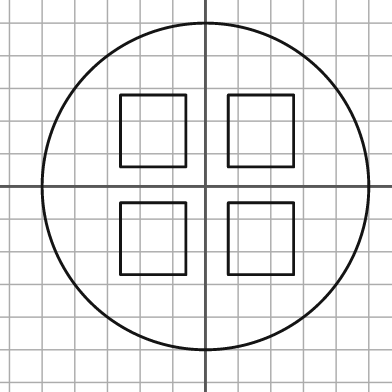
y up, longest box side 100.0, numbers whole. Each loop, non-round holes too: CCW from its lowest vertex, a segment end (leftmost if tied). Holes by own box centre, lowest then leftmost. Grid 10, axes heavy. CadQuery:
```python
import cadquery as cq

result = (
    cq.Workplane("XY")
    .moveTo(0.0, 0.0)
    .circle(50.0)
    .moveTo(-26.0, -27.0)
    .lineTo(-6.0, -27.0)
    .lineTo(-6.0, -5.0)
    .lineTo(-26.0, -5.0)
    .close()
    .moveTo(7.0, -27.0)
    .lineTo(27.0, -27.0)
    .lineTo(27.0, -5.0)
    .lineTo(7.0, -5.0)
    .close()
    .moveTo(-26.0, 6.0)
    .lineTo(-6.0, 6.0)
    .lineTo(-6.0, 28.0)
    .lineTo(-26.0, 28.0)
    .close()
    .moveTo(7.0, 6.0)
    .lineTo(27.0, 6.0)
    .lineTo(27.0, 28.0)
    .lineTo(7.0, 28.0)
    .close()
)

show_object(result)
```